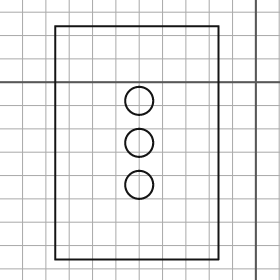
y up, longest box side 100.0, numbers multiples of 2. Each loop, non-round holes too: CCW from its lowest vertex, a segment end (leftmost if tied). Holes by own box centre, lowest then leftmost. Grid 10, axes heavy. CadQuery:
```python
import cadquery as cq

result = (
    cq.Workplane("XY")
    .moveTo(-86.0, -76.0)
    .lineTo(-16.0, -76.0)
    .lineTo(-16.0, 24.0)
    .lineTo(-86.0, 24.0)
    .close()
    .moveTo(-50.0, -44.0)
    .circle(6.0)
    .moveTo(-50.0, -26.0)
    .circle(6.0)
    .moveTo(-50.0, -8.0)
    .circle(6.0)
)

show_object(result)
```